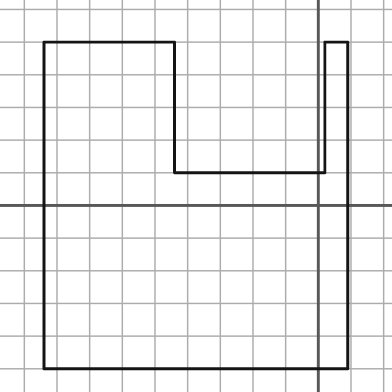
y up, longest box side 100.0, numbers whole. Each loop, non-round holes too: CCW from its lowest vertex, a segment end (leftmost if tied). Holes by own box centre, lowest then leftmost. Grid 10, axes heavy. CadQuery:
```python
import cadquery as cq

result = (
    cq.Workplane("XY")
    .moveTo(-84.0, -50.0)
    .lineTo(9.0, -50.0)
    .lineTo(9.0, 50.0)
    .lineTo(2.0, 50.0)
    .lineTo(2.0, 10.0)
    .lineTo(-44.0, 10.0)
    .lineTo(-44.0, 50.0)
    .lineTo(-84.0, 50.0)
    .close()
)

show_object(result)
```